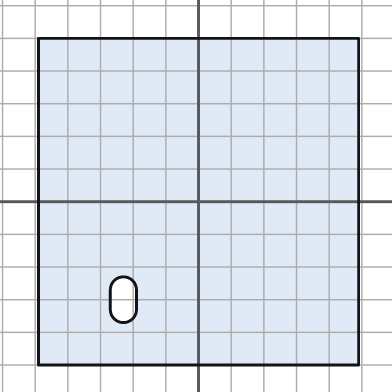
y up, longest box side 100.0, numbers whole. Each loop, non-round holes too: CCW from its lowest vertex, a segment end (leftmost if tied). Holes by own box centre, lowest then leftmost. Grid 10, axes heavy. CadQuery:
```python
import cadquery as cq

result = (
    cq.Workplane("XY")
    .moveTo(-49.0, -50.0)
    .lineTo(49.0, -50.0)
    .lineTo(49.0, 50.0)
    .lineTo(-49.0, 50.0)
    .close()
    .moveTo(-27.0, -33.0)
    .threePointArc((-23.0, -37.0), (-19.0, -33.0))
    .lineTo(-19.0, -27.0)
    .threePointArc((-23.0, -23.0), (-27.0, -27.0))
    .close()
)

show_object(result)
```